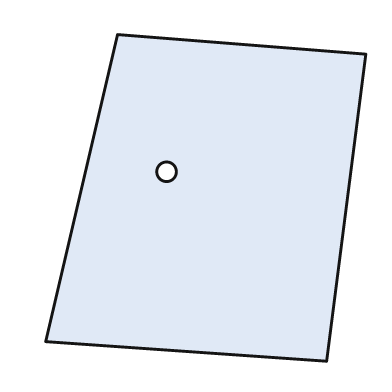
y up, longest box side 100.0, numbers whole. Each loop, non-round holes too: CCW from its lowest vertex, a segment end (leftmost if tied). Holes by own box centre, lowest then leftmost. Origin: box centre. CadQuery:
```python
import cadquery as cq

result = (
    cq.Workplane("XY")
    .moveTo(37.0, -50.0)
    .lineTo(49.0, 44.0)
    .lineTo(-27.0, 50.0)
    .lineTo(-49.0, -44.0)
    .close()
    .moveTo(-12.0, 8.0)
    .circle(3.0)
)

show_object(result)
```